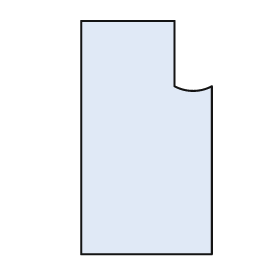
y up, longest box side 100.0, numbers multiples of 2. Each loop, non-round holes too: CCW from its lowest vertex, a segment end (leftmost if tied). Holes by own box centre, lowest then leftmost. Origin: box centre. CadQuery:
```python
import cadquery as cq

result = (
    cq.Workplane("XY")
    .moveTo(-28.0, -50.0)
    .lineTo(28.0, -50.0)
    .lineTo(28.0, 22.0)
    .threePointArc((20.0, 20.0), (12.0, 22.0))
    .lineTo(12.0, 50.0)
    .lineTo(-28.0, 50.0)
    .close()
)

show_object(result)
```